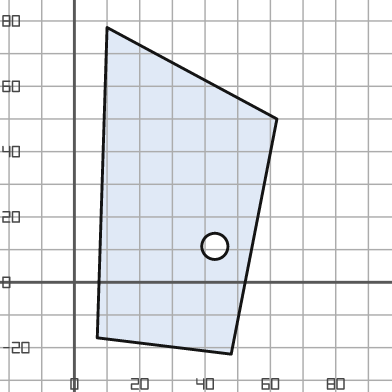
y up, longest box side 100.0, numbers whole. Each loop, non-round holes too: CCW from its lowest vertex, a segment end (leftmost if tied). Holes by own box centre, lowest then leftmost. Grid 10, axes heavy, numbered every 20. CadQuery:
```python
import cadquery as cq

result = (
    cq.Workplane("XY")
    .moveTo(48.0, -22.0)
    .lineTo(62.0, 50.0)
    .lineTo(10.0, 78.0)
    .lineTo(7.0, -17.0)
    .close()
    .moveTo(43.0, 11.0)
    .circle(4.0)
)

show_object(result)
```